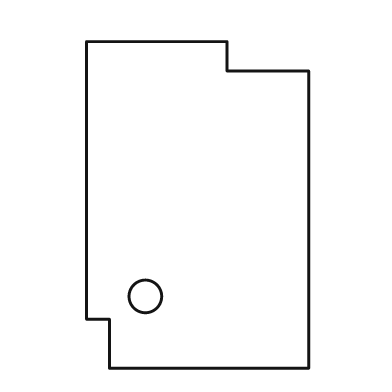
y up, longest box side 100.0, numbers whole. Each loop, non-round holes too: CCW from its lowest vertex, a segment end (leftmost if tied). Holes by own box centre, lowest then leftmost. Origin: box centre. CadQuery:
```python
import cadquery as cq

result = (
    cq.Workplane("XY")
    .moveTo(-27.0, -50.0)
    .lineTo(34.0, -50.0)
    .lineTo(34.0, 41.0)
    .lineTo(9.0, 41.0)
    .lineTo(9.0, 50.0)
    .lineTo(-34.0, 50.0)
    .lineTo(-34.0, -35.0)
    .lineTo(-27.0, -35.0)
    .close()
    .moveTo(-16.0, -28.0)
    .circle(5.0)
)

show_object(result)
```